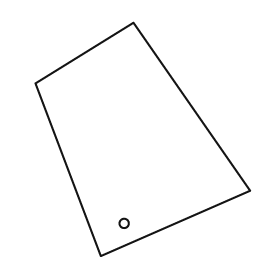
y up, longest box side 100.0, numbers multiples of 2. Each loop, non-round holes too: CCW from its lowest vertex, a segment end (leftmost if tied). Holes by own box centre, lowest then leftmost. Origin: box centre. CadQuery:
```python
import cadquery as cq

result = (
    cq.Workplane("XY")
    .moveTo(-18.0, -50.0)
    .lineTo(46.0, -22.0)
    .lineTo(-4.0, 50.0)
    .lineTo(-46.0, 24.0)
    .close()
    .moveTo(-8.0, -36.0)
    .circle(2.0)
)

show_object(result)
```